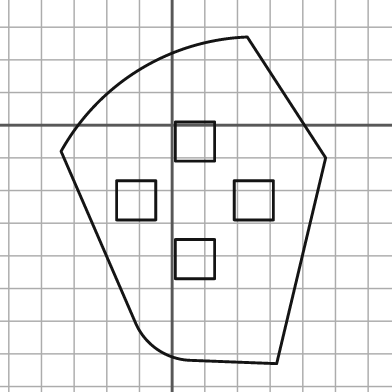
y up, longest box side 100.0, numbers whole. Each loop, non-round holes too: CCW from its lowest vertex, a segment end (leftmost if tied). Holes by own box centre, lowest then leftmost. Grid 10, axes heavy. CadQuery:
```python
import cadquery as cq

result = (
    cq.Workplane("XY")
    .moveTo(32.0, -73.0)
    .lineTo(47.0, -10.0)
    .lineTo(23.0, 27.0)
    .threePointArc((-10.0, 17.0), (-34.0, -8.0))
    .lineTo(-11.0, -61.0)
    .threePointArc((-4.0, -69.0), (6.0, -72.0))
    .close()
    .moveTo(1.0, -47.0)
    .lineTo(13.0, -47.0)
    .lineTo(13.0, -35.0)
    .lineTo(1.0, -35.0)
    .close()
    .moveTo(-17.0, -29.0)
    .lineTo(-5.0, -29.0)
    .lineTo(-5.0, -17.0)
    .lineTo(-17.0, -17.0)
    .close()
    .moveTo(19.0, -29.0)
    .lineTo(31.0, -29.0)
    .lineTo(31.0, -17.0)
    .lineTo(19.0, -17.0)
    .close()
    .moveTo(1.0, -11.0)
    .lineTo(13.0, -11.0)
    .lineTo(13.0, 1.0)
    .lineTo(1.0, 1.0)
    .close()
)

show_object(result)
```